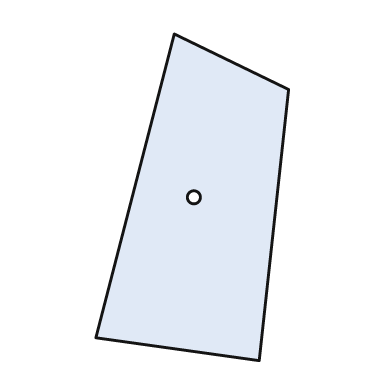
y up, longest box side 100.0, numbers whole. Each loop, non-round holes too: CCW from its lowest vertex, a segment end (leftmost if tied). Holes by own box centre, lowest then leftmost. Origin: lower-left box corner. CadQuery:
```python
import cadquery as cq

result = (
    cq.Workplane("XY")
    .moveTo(50.0, 0.0)
    .lineTo(59.0, 83.0)
    .lineTo(24.0, 100.0)
    .lineTo(0.0, 7.0)
    .close()
    .moveTo(30.0, 50.0)
    .circle(2.0)
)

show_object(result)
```